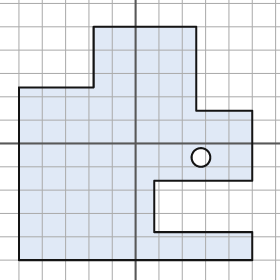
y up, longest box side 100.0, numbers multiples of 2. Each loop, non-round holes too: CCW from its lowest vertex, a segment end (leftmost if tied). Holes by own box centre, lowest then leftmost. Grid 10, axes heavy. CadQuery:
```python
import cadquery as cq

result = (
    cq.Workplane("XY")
    .moveTo(-50.0, -50.0)
    .lineTo(50.0, -50.0)
    .lineTo(50.0, -38.0)
    .lineTo(8.0, -38.0)
    .lineTo(8.0, -16.0)
    .lineTo(50.0, -16.0)
    .lineTo(50.0, 14.0)
    .lineTo(26.0, 14.0)
    .lineTo(26.0, 50.0)
    .lineTo(-18.0, 50.0)
    .lineTo(-18.0, 24.0)
    .lineTo(-50.0, 24.0)
    .close()
    .moveTo(28.0, -6.0)
    .circle(4.0)
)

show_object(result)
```